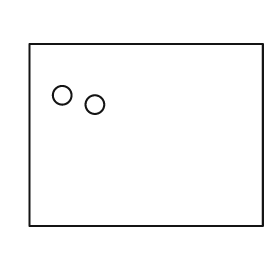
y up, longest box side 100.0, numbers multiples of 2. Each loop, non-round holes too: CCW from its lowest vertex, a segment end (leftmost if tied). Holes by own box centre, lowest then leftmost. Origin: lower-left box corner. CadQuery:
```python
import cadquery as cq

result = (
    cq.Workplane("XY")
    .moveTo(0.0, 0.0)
    .lineTo(100.0, 0.0)
    .lineTo(100.0, 78.0)
    .lineTo(0.0, 78.0)
    .close()
    .moveTo(28.0, 52.0)
    .circle(4.0)
    .moveTo(14.0, 56.0)
    .circle(4.0)
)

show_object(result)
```